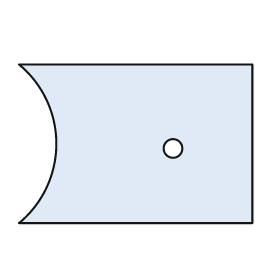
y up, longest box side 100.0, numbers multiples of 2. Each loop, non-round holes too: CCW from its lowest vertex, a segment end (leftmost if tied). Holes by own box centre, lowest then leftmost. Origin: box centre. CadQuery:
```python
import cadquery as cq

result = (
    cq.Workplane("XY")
    .moveTo(-50.0, -34.0)
    .lineTo(50.0, -34.0)
    .lineTo(50.0, 34.0)
    .lineTo(-50.0, 34.0)
    .threePointArc((-34.0, 0.0), (-50.0, -34.0))
    .close()
    .moveTo(16.0, -2.0)
    .circle(4.0)
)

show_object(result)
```